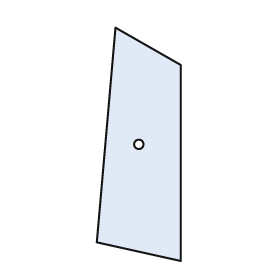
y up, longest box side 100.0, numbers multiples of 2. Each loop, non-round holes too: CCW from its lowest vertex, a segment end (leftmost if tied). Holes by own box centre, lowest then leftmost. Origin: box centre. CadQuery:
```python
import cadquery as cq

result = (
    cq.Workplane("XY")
    .moveTo(18.0, -50.0)
    .lineTo(18.0, 34.0)
    .lineTo(-10.0, 50.0)
    .lineTo(-18.0, -42.0)
    .close()
    .moveTo(0.0, 0.0)
    .circle(2.0)
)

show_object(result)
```